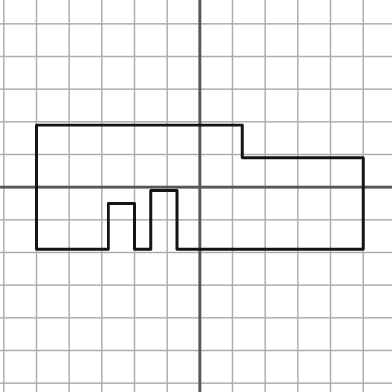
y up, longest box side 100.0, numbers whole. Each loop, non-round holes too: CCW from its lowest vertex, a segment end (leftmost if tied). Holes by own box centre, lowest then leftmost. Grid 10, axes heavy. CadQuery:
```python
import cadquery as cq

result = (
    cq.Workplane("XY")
    .moveTo(-50.0, -19.0)
    .lineTo(-28.0, -19.0)
    .lineTo(-28.0, -5.0)
    .lineTo(-20.0, -5.0)
    .lineTo(-20.0, -19.0)
    .lineTo(-15.0, -19.0)
    .lineTo(-15.0, -1.0)
    .lineTo(-7.0, -1.0)
    .lineTo(-7.0, -19.0)
    .lineTo(50.0, -19.0)
    .lineTo(50.0, 9.0)
    .lineTo(13.0, 9.0)
    .lineTo(13.0, 19.0)
    .lineTo(-50.0, 19.0)
    .close()
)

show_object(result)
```